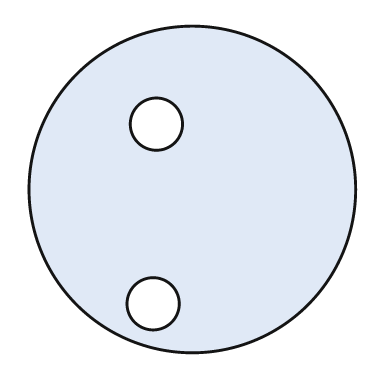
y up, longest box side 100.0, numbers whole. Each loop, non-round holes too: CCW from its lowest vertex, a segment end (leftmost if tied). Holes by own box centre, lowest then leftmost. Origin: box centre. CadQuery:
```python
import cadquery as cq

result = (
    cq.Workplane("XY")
    .moveTo(0.0, 0.0)
    .circle(50.0)
    .moveTo(-12.0, -35.0)
    .circle(8.0)
    .moveTo(-11.0, 20.0)
    .circle(8.0)
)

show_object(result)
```